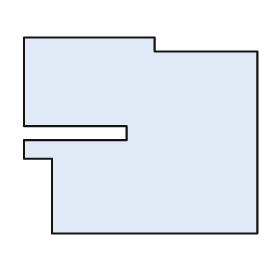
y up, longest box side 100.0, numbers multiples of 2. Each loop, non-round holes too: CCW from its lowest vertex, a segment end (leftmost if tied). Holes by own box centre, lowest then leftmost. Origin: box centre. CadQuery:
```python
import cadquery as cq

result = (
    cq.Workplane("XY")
    .moveTo(-38.0, -42.0)
    .lineTo(50.0, -42.0)
    .lineTo(50.0, 36.0)
    .lineTo(6.0, 36.0)
    .lineTo(6.0, 42.0)
    .lineTo(-50.0, 42.0)
    .lineTo(-50.0, 4.0)
    .lineTo(-6.0, 4.0)
    .lineTo(-6.0, -2.0)
    .lineTo(-50.0, -2.0)
    .lineTo(-50.0, -10.0)
    .lineTo(-38.0, -10.0)
    .close()
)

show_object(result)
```